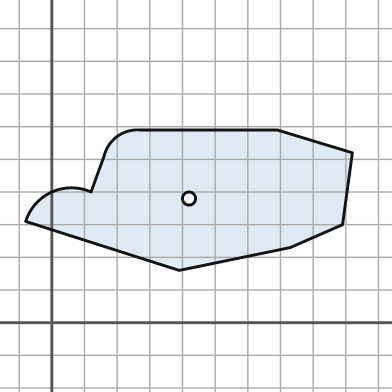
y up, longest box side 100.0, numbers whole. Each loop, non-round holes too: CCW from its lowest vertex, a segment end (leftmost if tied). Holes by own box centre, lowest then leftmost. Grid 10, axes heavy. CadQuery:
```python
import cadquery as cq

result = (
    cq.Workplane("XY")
    .moveTo(39.0, 16.0)
    .lineTo(73.0, 23.0)
    .lineTo(89.0, 30.0)
    .lineTo(92.0, 52.0)
    .lineTo(69.0, 59.0)
    .lineTo(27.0, 59.0)
    .threePointArc((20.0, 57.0), (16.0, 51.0))
    .lineTo(12.0, 40.0)
    .threePointArc((0.0, 40.0), (-8.0, 31.0))
    .close()
    .moveTo(42.0, 38.0)
    .circle(2.0)
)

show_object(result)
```